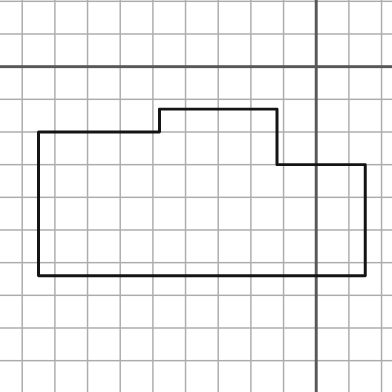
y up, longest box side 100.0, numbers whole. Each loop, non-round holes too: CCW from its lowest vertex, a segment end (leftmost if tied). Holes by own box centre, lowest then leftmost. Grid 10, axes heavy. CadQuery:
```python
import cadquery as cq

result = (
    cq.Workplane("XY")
    .moveTo(-85.0, -64.0)
    .lineTo(15.0, -64.0)
    .lineTo(15.0, -30.0)
    .lineTo(-12.0, -30.0)
    .lineTo(-12.0, -13.0)
    .lineTo(-48.0, -13.0)
    .lineTo(-48.0, -20.0)
    .lineTo(-85.0, -20.0)
    .close()
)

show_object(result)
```